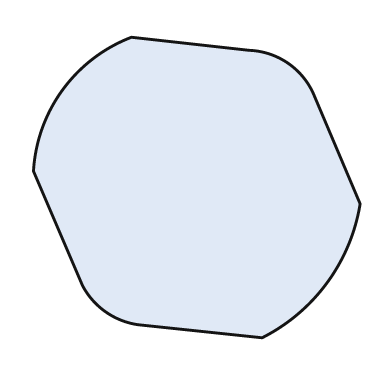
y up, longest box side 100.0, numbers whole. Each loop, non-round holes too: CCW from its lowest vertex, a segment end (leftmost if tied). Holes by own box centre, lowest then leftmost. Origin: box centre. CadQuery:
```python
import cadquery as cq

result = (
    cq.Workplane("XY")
    .moveTo(20.0, -46.0)
    .threePointArc((40.0, -29.0), (50.0, -5.0))
    .lineTo(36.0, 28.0)
    .threePointArc((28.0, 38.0), (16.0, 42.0))
    .lineTo(-20.0, 46.0)
    .threePointArc((-41.0, 30.0), (-50.0, 5.0))
    .lineTo(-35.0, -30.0)
    .threePointArc((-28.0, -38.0), (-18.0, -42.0))
    .close()
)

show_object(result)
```